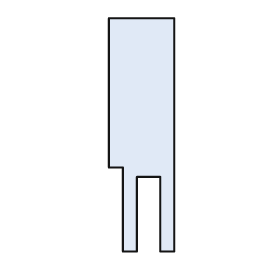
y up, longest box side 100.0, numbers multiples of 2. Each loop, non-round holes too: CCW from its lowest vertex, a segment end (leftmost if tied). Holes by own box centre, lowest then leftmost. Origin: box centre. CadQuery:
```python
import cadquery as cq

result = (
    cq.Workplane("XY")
    .moveTo(-8.0, -50.0)
    .lineTo(-2.0, -50.0)
    .lineTo(-2.0, -18.0)
    .lineTo(8.0, -18.0)
    .lineTo(8.0, -50.0)
    .lineTo(14.0, -50.0)
    .lineTo(14.0, 50.0)
    .lineTo(-14.0, 50.0)
    .lineTo(-14.0, -14.0)
    .lineTo(-8.0, -14.0)
    .close()
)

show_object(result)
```